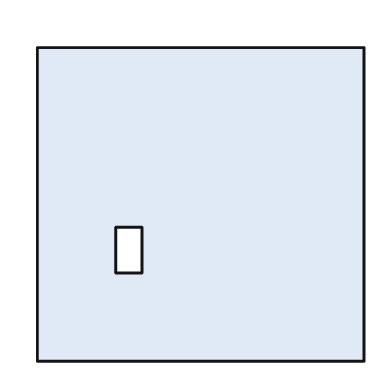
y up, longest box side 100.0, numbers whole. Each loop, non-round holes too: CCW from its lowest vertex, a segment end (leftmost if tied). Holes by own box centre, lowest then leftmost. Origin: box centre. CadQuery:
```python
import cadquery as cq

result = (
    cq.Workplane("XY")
    .moveTo(-50.0, -48.0)
    .lineTo(50.0, -48.0)
    .lineTo(50.0, 48.0)
    .lineTo(-50.0, 48.0)
    .close()
    .moveTo(-26.0, -21.0)
    .lineTo(-18.0, -21.0)
    .lineTo(-18.0, -7.0)
    .lineTo(-26.0, -7.0)
    .close()
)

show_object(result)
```